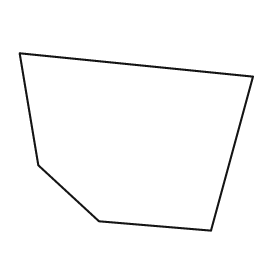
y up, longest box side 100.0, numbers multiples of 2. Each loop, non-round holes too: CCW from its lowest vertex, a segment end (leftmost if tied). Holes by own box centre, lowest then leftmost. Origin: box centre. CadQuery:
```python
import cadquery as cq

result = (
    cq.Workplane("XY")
    .moveTo(32.0, -38.0)
    .lineTo(50.0, 28.0)
    .lineTo(-50.0, 38.0)
    .lineTo(-42.0, -10.0)
    .lineTo(-16.0, -34.0)
    .close()
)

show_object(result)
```